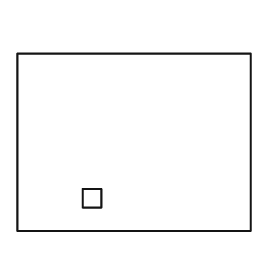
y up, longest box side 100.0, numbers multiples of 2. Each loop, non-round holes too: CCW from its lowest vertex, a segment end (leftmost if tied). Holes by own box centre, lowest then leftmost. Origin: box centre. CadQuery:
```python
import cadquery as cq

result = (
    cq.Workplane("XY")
    .moveTo(-50.0, -38.0)
    .lineTo(50.0, -38.0)
    .lineTo(50.0, 38.0)
    .lineTo(-50.0, 38.0)
    .close()
    .moveTo(-22.0, -28.0)
    .lineTo(-14.0, -28.0)
    .lineTo(-14.0, -20.0)
    .lineTo(-22.0, -20.0)
    .close()
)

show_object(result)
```